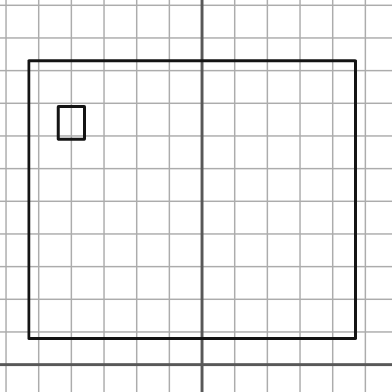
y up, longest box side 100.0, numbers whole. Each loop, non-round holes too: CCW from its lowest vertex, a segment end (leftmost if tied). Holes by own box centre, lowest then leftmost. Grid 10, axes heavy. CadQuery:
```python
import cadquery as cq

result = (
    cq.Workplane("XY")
    .moveTo(-53.0, 8.0)
    .lineTo(47.0, 8.0)
    .lineTo(47.0, 93.0)
    .lineTo(-53.0, 93.0)
    .close()
    .moveTo(-44.0, 69.0)
    .lineTo(-36.0, 69.0)
    .lineTo(-36.0, 79.0)
    .lineTo(-44.0, 79.0)
    .close()
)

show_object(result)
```